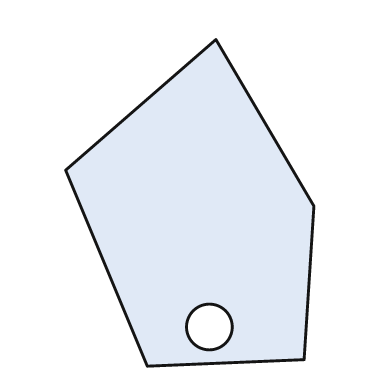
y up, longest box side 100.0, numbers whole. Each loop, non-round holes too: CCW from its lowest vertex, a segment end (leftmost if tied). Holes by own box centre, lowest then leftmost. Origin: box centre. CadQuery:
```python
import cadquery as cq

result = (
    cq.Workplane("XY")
    .moveTo(-13.0, -50.0)
    .lineTo(35.0, -48.0)
    .lineTo(38.0, -1.0)
    .lineTo(8.0, 50.0)
    .lineTo(-38.0, 10.0)
    .close()
    .moveTo(6.0, -38.0)
    .circle(7.0)
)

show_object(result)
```